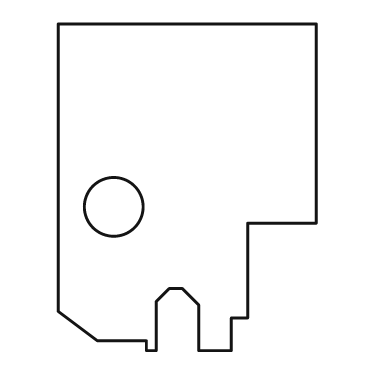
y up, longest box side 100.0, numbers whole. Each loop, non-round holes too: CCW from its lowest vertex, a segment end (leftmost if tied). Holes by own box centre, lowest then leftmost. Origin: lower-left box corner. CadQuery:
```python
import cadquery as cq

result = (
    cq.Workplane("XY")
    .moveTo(27.0, 0.0)
    .lineTo(30.0, 0.0)
    .lineTo(30.0, 15.0)
    .lineTo(34.0, 19.0)
    .lineTo(38.0, 19.0)
    .lineTo(43.0, 14.0)
    .lineTo(43.0, 0.0)
    .lineTo(53.0, 0.0)
    .lineTo(53.0, 10.0)
    .lineTo(58.0, 10.0)
    .lineTo(58.0, 39.0)
    .lineTo(79.0, 39.0)
    .lineTo(79.0, 100.0)
    .lineTo(0.0, 100.0)
    .lineTo(0.0, 12.0)
    .lineTo(12.0, 3.0)
    .lineTo(27.0, 3.0)
    .close()
    .moveTo(17.0, 44.0)
    .circle(9.0)
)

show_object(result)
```